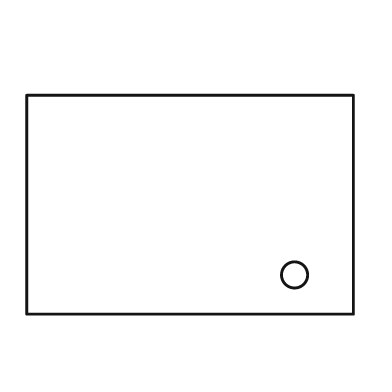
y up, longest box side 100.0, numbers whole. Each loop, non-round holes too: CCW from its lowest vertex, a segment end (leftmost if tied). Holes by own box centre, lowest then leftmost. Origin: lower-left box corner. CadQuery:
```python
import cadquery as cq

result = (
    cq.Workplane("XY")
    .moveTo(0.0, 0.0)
    .lineTo(100.0, 0.0)
    .lineTo(100.0, 67.0)
    .lineTo(0.0, 67.0)
    .close()
    .moveTo(82.0, 12.0)
    .circle(4.0)
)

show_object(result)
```